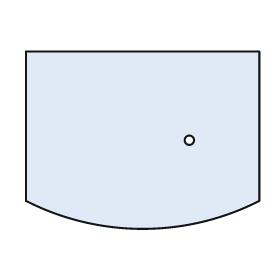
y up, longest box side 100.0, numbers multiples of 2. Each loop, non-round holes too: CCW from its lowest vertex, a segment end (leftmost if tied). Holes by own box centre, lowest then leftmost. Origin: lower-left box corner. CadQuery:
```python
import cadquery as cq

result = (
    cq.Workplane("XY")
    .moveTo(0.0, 12.0)
    .threePointArc((50.0, 0.0), (100.0, 12.0))
    .lineTo(100.0, 76.0)
    .lineTo(0.0, 76.0)
    .close()
    .moveTo(70.0, 38.0)
    .circle(2.0)
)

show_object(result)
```